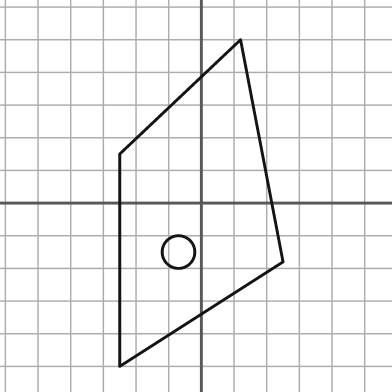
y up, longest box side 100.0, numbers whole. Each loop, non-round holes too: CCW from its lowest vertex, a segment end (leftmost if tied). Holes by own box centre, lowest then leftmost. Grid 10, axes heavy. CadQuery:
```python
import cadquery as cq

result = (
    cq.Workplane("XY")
    .moveTo(-25.0, -50.0)
    .lineTo(25.0, -18.0)
    .lineTo(12.0, 50.0)
    .lineTo(-25.0, 15.0)
    .close()
    .moveTo(-7.0, -15.0)
    .circle(5.0)
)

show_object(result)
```